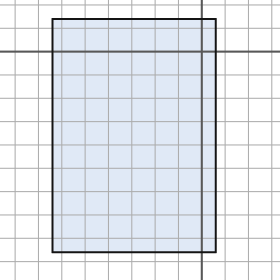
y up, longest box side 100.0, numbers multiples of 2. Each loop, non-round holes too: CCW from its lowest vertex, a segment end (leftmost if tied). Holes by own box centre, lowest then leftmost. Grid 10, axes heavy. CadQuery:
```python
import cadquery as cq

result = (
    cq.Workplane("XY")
    .moveTo(-64.0, -86.0)
    .lineTo(6.0, -86.0)
    .lineTo(6.0, 14.0)
    .lineTo(-64.0, 14.0)
    .close()
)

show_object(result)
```